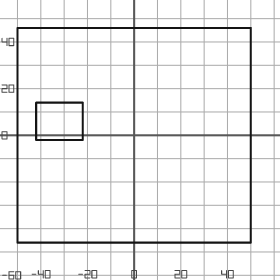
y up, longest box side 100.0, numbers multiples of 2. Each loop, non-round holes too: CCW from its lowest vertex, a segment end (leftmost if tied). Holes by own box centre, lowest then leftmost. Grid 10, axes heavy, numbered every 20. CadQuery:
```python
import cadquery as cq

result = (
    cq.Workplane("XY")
    .moveTo(-50.0, -46.0)
    .lineTo(50.0, -46.0)
    .lineTo(50.0, 46.0)
    .lineTo(-50.0, 46.0)
    .close()
    .moveTo(-42.0, -2.0)
    .lineTo(-22.0, -2.0)
    .lineTo(-22.0, 14.0)
    .lineTo(-42.0, 14.0)
    .close()
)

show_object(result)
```